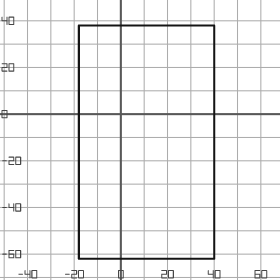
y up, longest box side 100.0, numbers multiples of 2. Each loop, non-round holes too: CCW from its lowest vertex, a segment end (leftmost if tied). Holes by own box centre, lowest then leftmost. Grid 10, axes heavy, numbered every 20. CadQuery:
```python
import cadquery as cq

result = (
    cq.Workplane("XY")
    .moveTo(-18.0, -62.0)
    .lineTo(40.0, -62.0)
    .lineTo(40.0, 38.0)
    .lineTo(-18.0, 38.0)
    .close()
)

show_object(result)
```